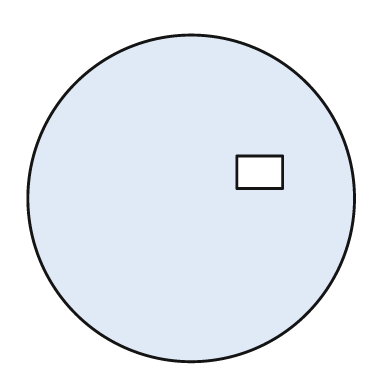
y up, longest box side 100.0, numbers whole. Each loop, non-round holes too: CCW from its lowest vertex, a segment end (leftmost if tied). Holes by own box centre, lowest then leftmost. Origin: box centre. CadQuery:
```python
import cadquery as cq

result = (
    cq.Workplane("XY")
    .moveTo(0.0, 0.0)
    .circle(50.0)
    .moveTo(14.0, 3.0)
    .lineTo(28.0, 3.0)
    .lineTo(28.0, 13.0)
    .lineTo(14.0, 13.0)
    .close()
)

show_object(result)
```